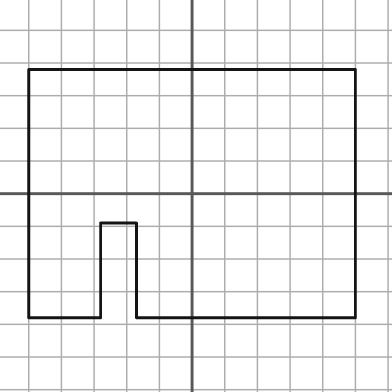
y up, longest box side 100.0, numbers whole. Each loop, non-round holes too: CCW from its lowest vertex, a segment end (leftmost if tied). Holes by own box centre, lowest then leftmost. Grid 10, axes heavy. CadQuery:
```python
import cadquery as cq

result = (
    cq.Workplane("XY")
    .moveTo(-50.0, -38.0)
    .lineTo(-28.0, -38.0)
    .lineTo(-28.0, -9.0)
    .lineTo(-17.0, -9.0)
    .lineTo(-17.0, -38.0)
    .lineTo(50.0, -38.0)
    .lineTo(50.0, 38.0)
    .lineTo(-50.0, 38.0)
    .close()
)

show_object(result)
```